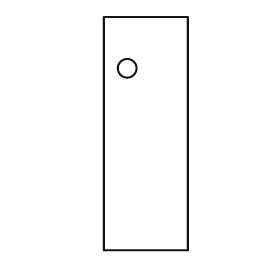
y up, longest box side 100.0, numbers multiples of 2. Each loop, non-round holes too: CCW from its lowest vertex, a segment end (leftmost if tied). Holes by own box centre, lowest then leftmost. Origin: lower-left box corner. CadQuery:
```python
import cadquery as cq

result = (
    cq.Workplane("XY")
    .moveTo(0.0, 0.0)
    .lineTo(36.0, 0.0)
    .lineTo(36.0, 100.0)
    .lineTo(0.0, 100.0)
    .close()
    .moveTo(10.0, 78.0)
    .circle(4.0)
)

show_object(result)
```